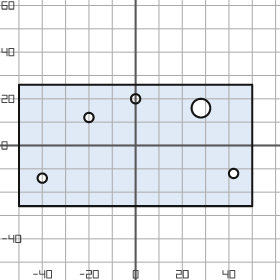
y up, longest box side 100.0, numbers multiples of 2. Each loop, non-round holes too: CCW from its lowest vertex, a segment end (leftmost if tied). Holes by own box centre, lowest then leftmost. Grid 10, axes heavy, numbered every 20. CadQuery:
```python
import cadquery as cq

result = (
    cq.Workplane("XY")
    .moveTo(-50.0, -26.0)
    .lineTo(50.0, -26.0)
    .lineTo(50.0, 26.0)
    .lineTo(-50.0, 26.0)
    .close()
    .moveTo(-40.0, -14.0)
    .circle(2.0)
    .moveTo(42.0, -12.0)
    .circle(2.0)
    .moveTo(-20.0, 12.0)
    .circle(2.0)
    .moveTo(28.0, 16.0)
    .circle(4.0)
    .moveTo(0.0, 20.0)
    .circle(2.0)
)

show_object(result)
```